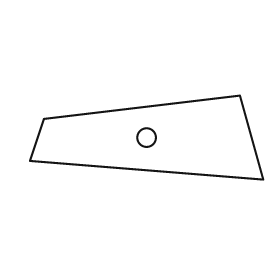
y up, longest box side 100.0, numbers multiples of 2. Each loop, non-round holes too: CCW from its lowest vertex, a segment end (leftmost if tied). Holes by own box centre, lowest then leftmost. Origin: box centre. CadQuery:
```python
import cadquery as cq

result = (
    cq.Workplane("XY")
    .moveTo(50.0, -18.0)
    .lineTo(40.0, 18.0)
    .lineTo(-44.0, 8.0)
    .lineTo(-50.0, -10.0)
    .close()
    .moveTo(0.0, 0.0)
    .circle(4.0)
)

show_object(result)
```